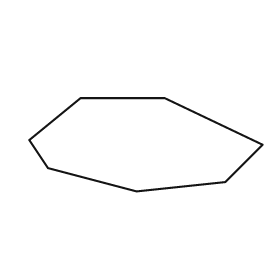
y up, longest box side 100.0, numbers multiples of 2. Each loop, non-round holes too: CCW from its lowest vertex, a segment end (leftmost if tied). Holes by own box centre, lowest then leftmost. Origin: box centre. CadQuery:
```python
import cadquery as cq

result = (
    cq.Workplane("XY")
    .moveTo(-4.0, -20.0)
    .lineTo(34.0, -16.0)
    .lineTo(50.0, 0.0)
    .lineTo(8.0, 20.0)
    .lineTo(-28.0, 20.0)
    .lineTo(-50.0, 2.0)
    .lineTo(-42.0, -10.0)
    .close()
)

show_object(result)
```